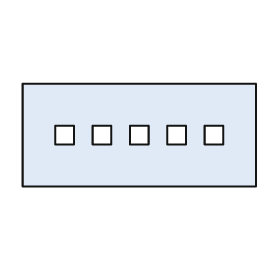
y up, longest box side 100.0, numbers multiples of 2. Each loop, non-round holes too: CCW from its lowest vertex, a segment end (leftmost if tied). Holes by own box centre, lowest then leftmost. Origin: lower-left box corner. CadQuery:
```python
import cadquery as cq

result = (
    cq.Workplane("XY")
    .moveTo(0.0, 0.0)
    .lineTo(100.0, 0.0)
    .lineTo(100.0, 44.0)
    .lineTo(0.0, 44.0)
    .close()
    .moveTo(14.0, 18.0)
    .lineTo(22.0, 18.0)
    .lineTo(22.0, 26.0)
    .lineTo(14.0, 26.0)
    .close()
    .moveTo(30.0, 18.0)
    .lineTo(38.0, 18.0)
    .lineTo(38.0, 26.0)
    .lineTo(30.0, 26.0)
    .close()
    .moveTo(46.0, 18.0)
    .lineTo(54.0, 18.0)
    .lineTo(54.0, 26.0)
    .lineTo(46.0, 26.0)
    .close()
    .moveTo(62.0, 18.0)
    .lineTo(70.0, 18.0)
    .lineTo(70.0, 26.0)
    .lineTo(62.0, 26.0)
    .close()
    .moveTo(78.0, 18.0)
    .lineTo(86.0, 18.0)
    .lineTo(86.0, 26.0)
    .lineTo(78.0, 26.0)
    .close()
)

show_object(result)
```